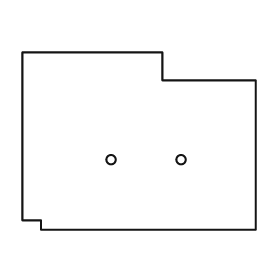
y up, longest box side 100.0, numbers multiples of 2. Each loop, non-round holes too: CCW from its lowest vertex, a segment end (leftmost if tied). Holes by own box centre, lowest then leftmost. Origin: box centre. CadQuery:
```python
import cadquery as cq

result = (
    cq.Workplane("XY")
    .moveTo(-42.0, -38.0)
    .lineTo(50.0, -38.0)
    .lineTo(50.0, 26.0)
    .lineTo(10.0, 26.0)
    .lineTo(10.0, 38.0)
    .lineTo(-50.0, 38.0)
    .lineTo(-50.0, -34.0)
    .lineTo(-42.0, -34.0)
    .close()
    .moveTo(-12.0, -8.0)
    .circle(2.0)
    .moveTo(18.0, -8.0)
    .circle(2.0)
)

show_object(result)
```